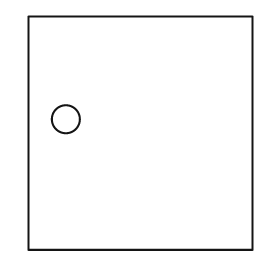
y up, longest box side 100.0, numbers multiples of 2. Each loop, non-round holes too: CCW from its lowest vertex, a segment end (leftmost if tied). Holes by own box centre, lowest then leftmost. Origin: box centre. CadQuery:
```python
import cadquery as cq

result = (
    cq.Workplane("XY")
    .moveTo(-48.0, -50.0)
    .lineTo(48.0, -50.0)
    .lineTo(48.0, 50.0)
    .lineTo(-48.0, 50.0)
    .close()
    .moveTo(-32.0, 6.0)
    .circle(6.0)
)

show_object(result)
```